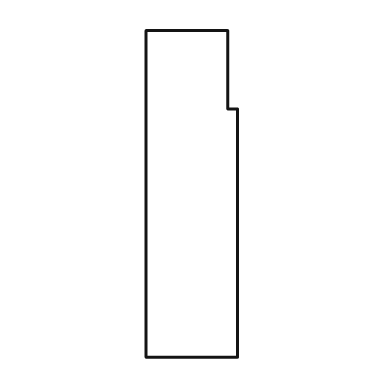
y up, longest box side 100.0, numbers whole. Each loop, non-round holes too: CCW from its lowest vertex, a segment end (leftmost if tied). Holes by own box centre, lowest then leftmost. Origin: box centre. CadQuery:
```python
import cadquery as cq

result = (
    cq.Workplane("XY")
    .moveTo(-14.0, -50.0)
    .lineTo(14.0, -50.0)
    .lineTo(14.0, 26.0)
    .lineTo(11.0, 26.0)
    .lineTo(11.0, 50.0)
    .lineTo(-14.0, 50.0)
    .close()
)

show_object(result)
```